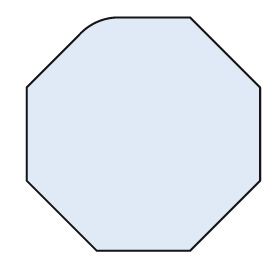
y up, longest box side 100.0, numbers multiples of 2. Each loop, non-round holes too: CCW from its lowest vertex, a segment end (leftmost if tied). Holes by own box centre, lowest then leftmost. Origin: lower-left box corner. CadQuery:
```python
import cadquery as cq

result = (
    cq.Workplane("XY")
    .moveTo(30.0, 0.0)
    .lineTo(70.0, 0.0)
    .lineTo(100.0, 30.0)
    .lineTo(100.0, 70.0)
    .lineTo(70.0, 100.0)
    .lineTo(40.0, 100.0)
    .threePointArc((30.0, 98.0), (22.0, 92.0))
    .lineTo(0.0, 70.0)
    .lineTo(0.0, 30.0)
    .close()
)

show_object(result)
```